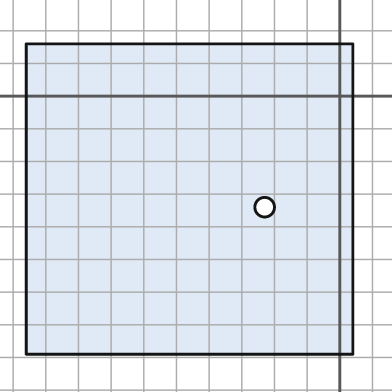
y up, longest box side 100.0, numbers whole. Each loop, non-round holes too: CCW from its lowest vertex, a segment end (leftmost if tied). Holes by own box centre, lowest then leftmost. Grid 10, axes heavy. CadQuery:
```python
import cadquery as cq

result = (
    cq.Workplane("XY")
    .moveTo(-96.0, -79.0)
    .lineTo(4.0, -79.0)
    .lineTo(4.0, 16.0)
    .lineTo(-96.0, 16.0)
    .close()
    .moveTo(-23.0, -34.0)
    .circle(3.0)
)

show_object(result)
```